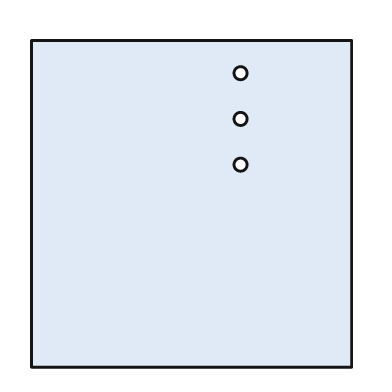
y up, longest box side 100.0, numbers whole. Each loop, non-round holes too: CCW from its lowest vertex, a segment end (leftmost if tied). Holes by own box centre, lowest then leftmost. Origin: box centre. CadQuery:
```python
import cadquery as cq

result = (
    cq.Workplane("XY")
    .moveTo(-49.0, -50.0)
    .lineTo(49.0, -50.0)
    .lineTo(49.0, 50.0)
    .lineTo(-49.0, 50.0)
    .close()
    .moveTo(15.0, 12.0)
    .circle(2.0)
    .moveTo(15.0, 26.0)
    .circle(2.0)
    .moveTo(15.0, 40.0)
    .circle(2.0)
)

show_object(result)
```